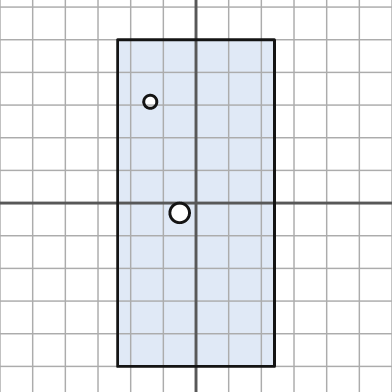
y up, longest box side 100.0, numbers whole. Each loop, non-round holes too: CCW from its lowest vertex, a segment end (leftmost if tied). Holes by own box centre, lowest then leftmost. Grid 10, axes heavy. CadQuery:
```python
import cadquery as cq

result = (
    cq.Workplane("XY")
    .moveTo(-24.0, -50.0)
    .lineTo(24.0, -50.0)
    .lineTo(24.0, 50.0)
    .lineTo(-24.0, 50.0)
    .close()
    .moveTo(-5.0, -3.0)
    .circle(3.0)
    .moveTo(-14.0, 31.0)
    .circle(2.0)
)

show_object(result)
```